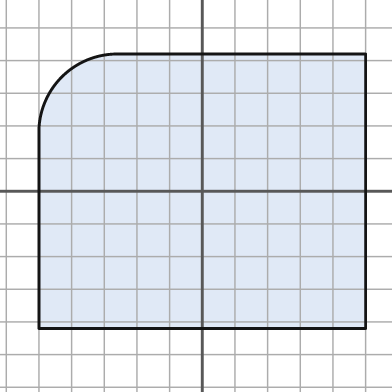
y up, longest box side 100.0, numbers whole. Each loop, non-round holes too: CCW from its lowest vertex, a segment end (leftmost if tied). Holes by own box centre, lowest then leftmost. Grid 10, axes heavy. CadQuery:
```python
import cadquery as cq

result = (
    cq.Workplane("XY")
    .moveTo(-50.0, -42.0)
    .lineTo(50.0, -42.0)
    .lineTo(50.0, 42.0)
    .lineTo(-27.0, 42.0)
    .threePointArc((-43.0, 35.0), (-50.0, 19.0))
    .close()
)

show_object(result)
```